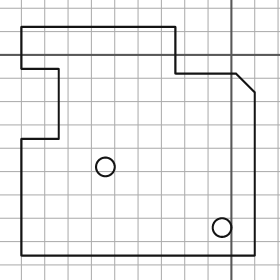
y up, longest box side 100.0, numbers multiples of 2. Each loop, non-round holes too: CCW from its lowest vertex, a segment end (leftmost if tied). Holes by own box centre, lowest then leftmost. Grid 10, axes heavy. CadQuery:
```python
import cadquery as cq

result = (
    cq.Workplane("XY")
    .moveTo(-90.0, -86.0)
    .lineTo(10.0, -86.0)
    .lineTo(10.0, -16.0)
    .lineTo(2.0, -8.0)
    .lineTo(-24.0, -8.0)
    .lineTo(-24.0, 12.0)
    .lineTo(-90.0, 12.0)
    .lineTo(-90.0, -6.0)
    .lineTo(-74.0, -6.0)
    .lineTo(-74.0, -36.0)
    .lineTo(-90.0, -36.0)
    .close()
    .moveTo(-4.0, -74.0)
    .circle(4.0)
    .moveTo(-54.0, -48.0)
    .circle(4.0)
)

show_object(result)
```